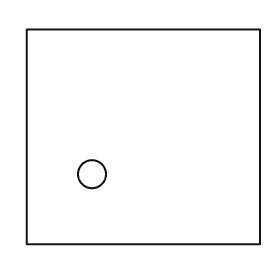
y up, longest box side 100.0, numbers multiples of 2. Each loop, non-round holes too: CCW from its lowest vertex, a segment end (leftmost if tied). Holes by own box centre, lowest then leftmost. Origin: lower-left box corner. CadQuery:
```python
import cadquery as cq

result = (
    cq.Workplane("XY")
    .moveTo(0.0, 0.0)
    .lineTo(100.0, 0.0)
    .lineTo(100.0, 92.0)
    .lineTo(0.0, 92.0)
    .close()
    .moveTo(28.0, 30.0)
    .circle(6.0)
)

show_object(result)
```